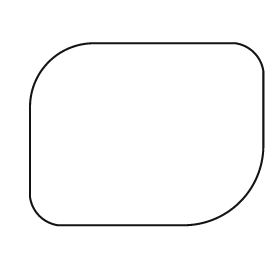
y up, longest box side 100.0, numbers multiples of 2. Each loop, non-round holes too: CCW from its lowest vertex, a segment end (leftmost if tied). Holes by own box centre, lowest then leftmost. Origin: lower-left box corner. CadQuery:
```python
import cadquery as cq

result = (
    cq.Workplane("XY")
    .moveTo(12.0, 0.0)
    .lineTo(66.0, 0.0)
    .threePointArc((90.0, 10.0), (100.0, 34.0))
    .lineTo(100.0, 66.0)
    .threePointArc((96.0, 74.0), (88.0, 78.0))
    .lineTo(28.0, 78.0)
    .threePointArc((8.0, 70.0), (0.0, 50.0))
    .lineTo(0.0, 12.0)
    .threePointArc((4.0, 4.0), (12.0, 0.0))
    .close()
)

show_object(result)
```